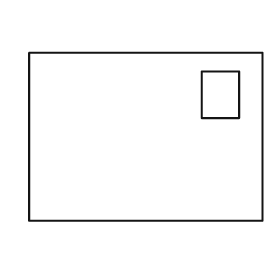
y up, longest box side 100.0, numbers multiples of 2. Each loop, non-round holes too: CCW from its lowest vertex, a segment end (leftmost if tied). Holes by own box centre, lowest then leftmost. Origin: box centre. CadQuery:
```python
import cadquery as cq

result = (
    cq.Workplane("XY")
    .moveTo(-50.0, -36.0)
    .lineTo(50.0, -36.0)
    .lineTo(50.0, 36.0)
    .lineTo(-50.0, 36.0)
    .close()
    .moveTo(24.0, 8.0)
    .lineTo(40.0, 8.0)
    .lineTo(40.0, 28.0)
    .lineTo(24.0, 28.0)
    .close()
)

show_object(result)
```